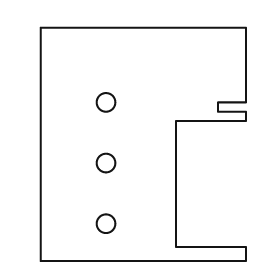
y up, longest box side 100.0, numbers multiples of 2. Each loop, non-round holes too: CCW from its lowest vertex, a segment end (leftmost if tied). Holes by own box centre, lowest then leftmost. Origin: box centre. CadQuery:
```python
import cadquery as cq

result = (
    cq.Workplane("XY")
    .moveTo(-44.0, -50.0)
    .lineTo(44.0, -50.0)
    .lineTo(44.0, -44.0)
    .lineTo(14.0, -44.0)
    .lineTo(14.0, 10.0)
    .lineTo(44.0, 10.0)
    .lineTo(44.0, 14.0)
    .lineTo(32.0, 14.0)
    .lineTo(32.0, 18.0)
    .lineTo(44.0, 18.0)
    .lineTo(44.0, 50.0)
    .lineTo(-44.0, 50.0)
    .close()
    .moveTo(-16.0, -34.0)
    .circle(4.0)
    .moveTo(-16.0, -8.0)
    .circle(4.0)
    .moveTo(-16.0, 18.0)
    .circle(4.0)
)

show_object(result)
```